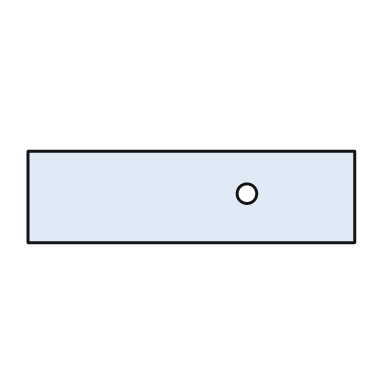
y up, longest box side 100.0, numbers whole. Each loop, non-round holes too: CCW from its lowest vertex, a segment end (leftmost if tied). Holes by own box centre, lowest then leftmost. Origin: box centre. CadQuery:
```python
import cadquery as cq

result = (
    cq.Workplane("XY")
    .moveTo(-50.0, -14.0)
    .lineTo(50.0, -14.0)
    .lineTo(50.0, 14.0)
    .lineTo(-50.0, 14.0)
    .close()
    .moveTo(17.0, 1.0)
    .circle(3.0)
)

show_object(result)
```